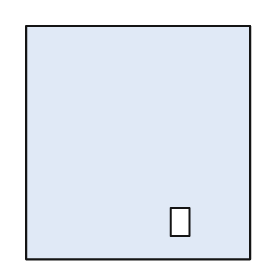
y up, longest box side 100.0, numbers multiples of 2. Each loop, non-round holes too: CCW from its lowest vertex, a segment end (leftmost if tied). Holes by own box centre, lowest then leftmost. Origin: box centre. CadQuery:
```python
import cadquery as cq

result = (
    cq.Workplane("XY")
    .moveTo(-48.0, -50.0)
    .lineTo(48.0, -50.0)
    .lineTo(48.0, 50.0)
    .lineTo(-48.0, 50.0)
    .close()
    .moveTo(14.0, -40.0)
    .lineTo(22.0, -40.0)
    .lineTo(22.0, -28.0)
    .lineTo(14.0, -28.0)
    .close()
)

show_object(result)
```